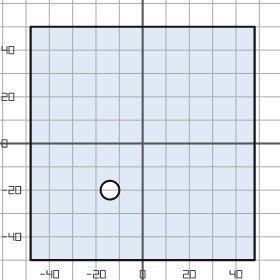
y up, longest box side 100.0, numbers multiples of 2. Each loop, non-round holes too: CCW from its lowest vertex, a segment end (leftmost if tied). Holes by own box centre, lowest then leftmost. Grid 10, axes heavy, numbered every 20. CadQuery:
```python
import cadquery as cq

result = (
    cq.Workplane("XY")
    .moveTo(-48.0, -50.0)
    .lineTo(48.0, -50.0)
    .lineTo(48.0, 50.0)
    .lineTo(-48.0, 50.0)
    .close()
    .moveTo(-14.0, -20.0)
    .circle(4.0)
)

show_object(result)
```